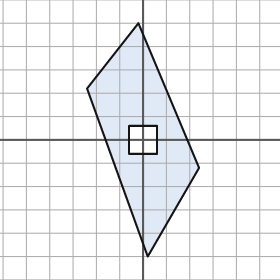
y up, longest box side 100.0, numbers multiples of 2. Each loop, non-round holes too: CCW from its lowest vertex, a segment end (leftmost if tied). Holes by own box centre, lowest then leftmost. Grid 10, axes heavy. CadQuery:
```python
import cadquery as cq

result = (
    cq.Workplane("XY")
    .moveTo(2.0, -50.0)
    .lineTo(24.0, -12.0)
    .lineTo(-2.0, 50.0)
    .lineTo(-24.0, 22.0)
    .close()
    .moveTo(-6.0, -6.0)
    .lineTo(6.0, -6.0)
    .lineTo(6.0, 6.0)
    .lineTo(-6.0, 6.0)
    .close()
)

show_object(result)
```